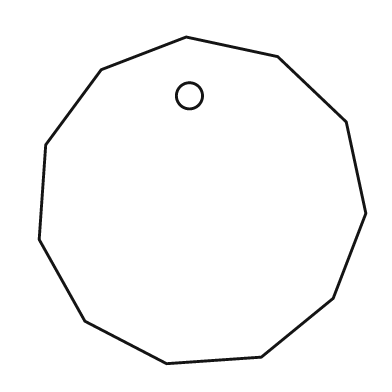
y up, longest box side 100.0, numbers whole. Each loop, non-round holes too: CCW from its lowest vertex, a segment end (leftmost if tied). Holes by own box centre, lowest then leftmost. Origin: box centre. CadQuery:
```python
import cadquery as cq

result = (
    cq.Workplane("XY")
    .moveTo(-11.0, -50.0)
    .lineTo(18.0, -48.0)
    .lineTo(40.0, -30.0)
    .lineTo(50.0, -4.0)
    .lineTo(44.0, 24.0)
    .lineTo(23.0, 44.0)
    .lineTo(-5.0, 50.0)
    .lineTo(-31.0, 40.0)
    .lineTo(-48.0, 17.0)
    .lineTo(-50.0, -12.0)
    .lineTo(-36.0, -37.0)
    .close()
    .moveTo(-4.0, 32.0)
    .circle(4.0)
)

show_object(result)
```